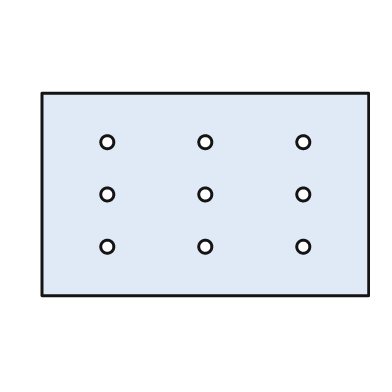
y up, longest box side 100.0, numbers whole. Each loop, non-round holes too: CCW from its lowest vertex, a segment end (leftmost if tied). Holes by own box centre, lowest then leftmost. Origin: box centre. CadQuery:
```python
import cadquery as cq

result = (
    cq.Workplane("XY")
    .moveTo(-50.0, -31.0)
    .lineTo(50.0, -31.0)
    .lineTo(50.0, 31.0)
    .lineTo(-50.0, 31.0)
    .close()
    .moveTo(-30.0, -16.0)
    .circle(2.0)
    .moveTo(0.0, -16.0)
    .circle(2.0)
    .moveTo(30.0, -16.0)
    .circle(2.0)
    .moveTo(-30.0, 0.0)
    .circle(2.0)
    .moveTo(0.0, 0.0)
    .circle(2.0)
    .moveTo(30.0, 0.0)
    .circle(2.0)
    .moveTo(-30.0, 16.0)
    .circle(2.0)
    .moveTo(0.0, 16.0)
    .circle(2.0)
    .moveTo(30.0, 16.0)
    .circle(2.0)
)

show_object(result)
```